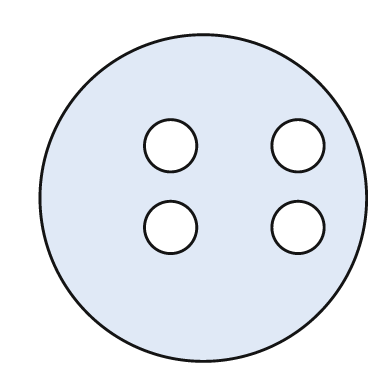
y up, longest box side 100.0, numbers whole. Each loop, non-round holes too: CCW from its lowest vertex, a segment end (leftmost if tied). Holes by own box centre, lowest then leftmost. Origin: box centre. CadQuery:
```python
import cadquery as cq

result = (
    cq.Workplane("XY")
    .moveTo(0.0, 0.0)
    .circle(50.0)
    .moveTo(-10.0, -9.0)
    .circle(8.0)
    .moveTo(29.0, -9.0)
    .circle(8.0)
    .moveTo(-10.0, 16.0)
    .circle(8.0)
    .moveTo(29.0, 16.0)
    .circle(8.0)
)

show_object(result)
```